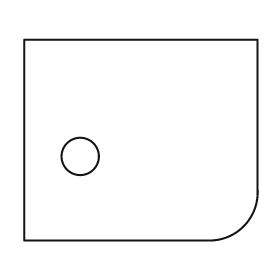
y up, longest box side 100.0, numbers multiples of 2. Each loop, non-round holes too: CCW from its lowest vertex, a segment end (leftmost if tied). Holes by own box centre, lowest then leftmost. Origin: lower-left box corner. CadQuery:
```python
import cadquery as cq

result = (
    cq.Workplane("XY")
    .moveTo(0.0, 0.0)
    .lineTo(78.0, 0.0)
    .threePointArc((94.0, 6.0), (100.0, 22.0))
    .lineTo(100.0, 86.0)
    .lineTo(0.0, 86.0)
    .close()
    .moveTo(24.0, 36.0)
    .circle(8.0)
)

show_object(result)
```